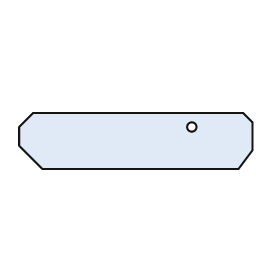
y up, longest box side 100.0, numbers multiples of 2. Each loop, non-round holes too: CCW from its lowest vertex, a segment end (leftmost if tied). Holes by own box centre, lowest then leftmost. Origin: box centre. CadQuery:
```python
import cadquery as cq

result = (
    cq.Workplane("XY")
    .moveTo(-40.0, -12.0)
    .lineTo(44.0, -12.0)
    .lineTo(50.0, -4.0)
    .lineTo(50.0, 8.0)
    .lineTo(46.0, 12.0)
    .lineTo(-44.0, 12.0)
    .lineTo(-50.0, 6.0)
    .lineTo(-50.0, -2.0)
    .close()
    .moveTo(24.0, 6.0)
    .circle(2.0)
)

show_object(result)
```